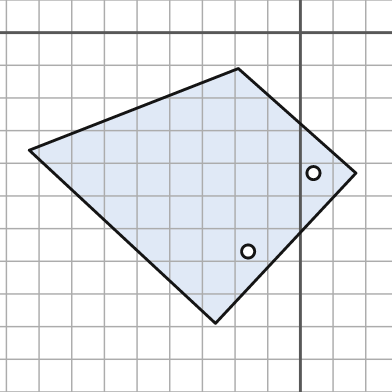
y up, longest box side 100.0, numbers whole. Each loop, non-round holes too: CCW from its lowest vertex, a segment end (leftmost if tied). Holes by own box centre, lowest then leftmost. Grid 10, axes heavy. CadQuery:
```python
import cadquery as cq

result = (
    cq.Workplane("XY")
    .moveTo(-26.0, -89.0)
    .lineTo(17.0, -43.0)
    .lineTo(-19.0, -11.0)
    .lineTo(-83.0, -36.0)
    .close()
    .moveTo(-16.0, -67.0)
    .circle(2.0)
    .moveTo(4.0, -43.0)
    .circle(2.0)
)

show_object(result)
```